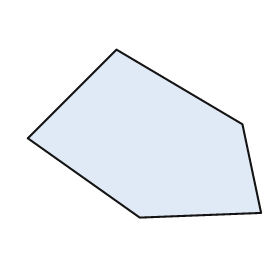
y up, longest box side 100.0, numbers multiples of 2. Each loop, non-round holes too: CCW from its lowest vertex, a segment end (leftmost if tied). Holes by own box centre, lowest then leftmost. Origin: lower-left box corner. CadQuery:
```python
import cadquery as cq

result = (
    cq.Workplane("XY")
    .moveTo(48.0, 0.0)
    .lineTo(100.0, 2.0)
    .lineTo(92.0, 40.0)
    .lineTo(38.0, 72.0)
    .lineTo(0.0, 34.0)
    .close()
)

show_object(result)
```